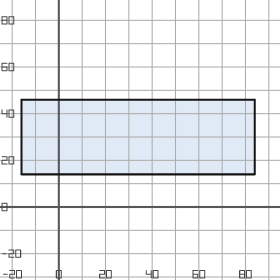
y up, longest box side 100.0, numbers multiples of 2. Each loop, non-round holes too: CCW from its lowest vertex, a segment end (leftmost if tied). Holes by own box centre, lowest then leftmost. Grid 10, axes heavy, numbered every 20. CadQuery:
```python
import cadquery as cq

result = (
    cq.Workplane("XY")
    .moveTo(-16.0, 14.0)
    .lineTo(84.0, 14.0)
    .lineTo(84.0, 46.0)
    .lineTo(-16.0, 46.0)
    .close()
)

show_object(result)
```